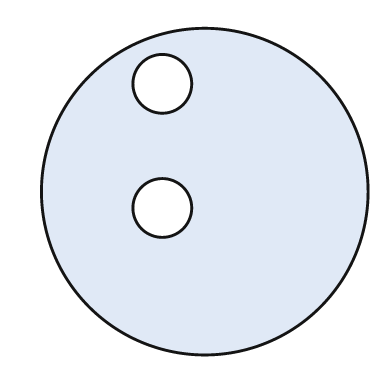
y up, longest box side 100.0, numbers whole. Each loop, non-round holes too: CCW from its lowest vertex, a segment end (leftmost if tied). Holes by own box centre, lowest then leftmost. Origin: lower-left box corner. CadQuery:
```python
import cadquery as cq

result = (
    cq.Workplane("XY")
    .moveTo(50.0, 50.0)
    .circle(50.0)
    .moveTo(37.0, 45.0)
    .circle(9.0)
    .moveTo(37.0, 83.0)
    .circle(9.0)
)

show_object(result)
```